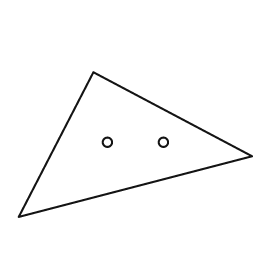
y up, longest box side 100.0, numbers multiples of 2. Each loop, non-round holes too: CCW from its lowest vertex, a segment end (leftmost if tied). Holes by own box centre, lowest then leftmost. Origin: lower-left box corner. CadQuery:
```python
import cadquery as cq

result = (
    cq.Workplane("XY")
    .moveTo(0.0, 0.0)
    .lineTo(100.0, 26.0)
    .lineTo(32.0, 62.0)
    .close()
    .moveTo(38.0, 32.0)
    .circle(2.0)
    .moveTo(62.0, 32.0)
    .circle(2.0)
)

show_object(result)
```